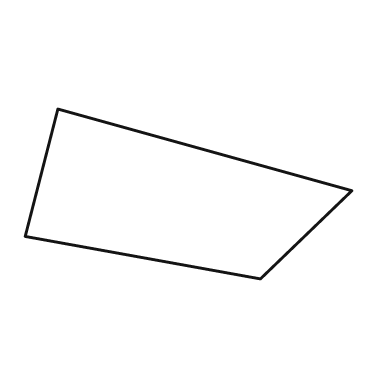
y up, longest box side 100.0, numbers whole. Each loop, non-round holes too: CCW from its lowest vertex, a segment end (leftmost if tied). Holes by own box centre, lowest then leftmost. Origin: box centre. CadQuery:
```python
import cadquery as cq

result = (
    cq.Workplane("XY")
    .moveTo(22.0, -26.0)
    .lineTo(50.0, 1.0)
    .lineTo(-40.0, 26.0)
    .lineTo(-50.0, -13.0)
    .close()
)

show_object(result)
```